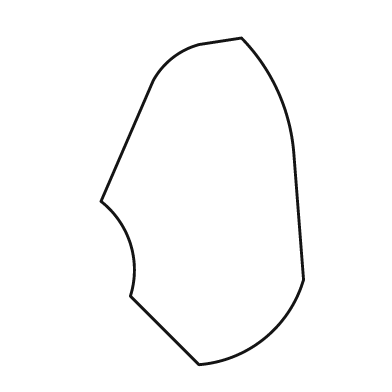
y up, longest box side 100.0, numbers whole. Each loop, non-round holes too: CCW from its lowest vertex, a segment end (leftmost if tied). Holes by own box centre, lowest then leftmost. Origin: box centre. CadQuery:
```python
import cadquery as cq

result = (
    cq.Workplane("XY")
    .moveTo(-1.0, -50.0)
    .threePointArc((19.0, -42.0), (31.0, -24.0))
    .lineTo(28.0, 15.0)
    .threePointArc((23.0, 34.0), (12.0, 50.0))
    .lineTo(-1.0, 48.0)
    .threePointArc((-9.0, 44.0), (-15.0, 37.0))
    .lineTo(-31.0, 0.0)
    .threePointArc((-22.0, -13.0), (-22.0, -29.0))
    .close()
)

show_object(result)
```